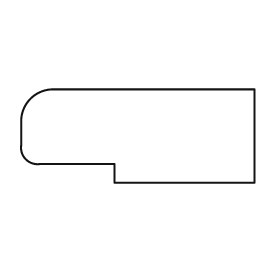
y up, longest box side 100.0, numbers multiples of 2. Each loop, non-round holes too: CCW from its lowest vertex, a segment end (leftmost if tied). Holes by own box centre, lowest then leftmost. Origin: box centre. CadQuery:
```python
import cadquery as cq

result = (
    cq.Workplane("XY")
    .moveTo(-10.0, -20.0)
    .lineTo(50.0, -20.0)
    .lineTo(50.0, 20.0)
    .lineTo(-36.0, 20.0)
    .threePointArc((-46.0, 16.0), (-50.0, 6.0))
    .lineTo(-50.0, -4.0)
    .threePointArc((-48.0, -10.0), (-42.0, -12.0))
    .lineTo(-10.0, -12.0)
    .close()
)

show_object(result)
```